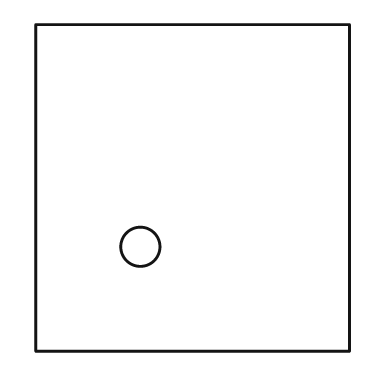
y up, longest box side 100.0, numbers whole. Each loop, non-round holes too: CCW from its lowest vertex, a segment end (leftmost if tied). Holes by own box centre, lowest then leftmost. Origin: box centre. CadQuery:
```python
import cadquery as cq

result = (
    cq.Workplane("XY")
    .moveTo(-48.0, -50.0)
    .lineTo(48.0, -50.0)
    .lineTo(48.0, 50.0)
    .lineTo(-48.0, 50.0)
    .close()
    .moveTo(-16.0, -18.0)
    .circle(6.0)
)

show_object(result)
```